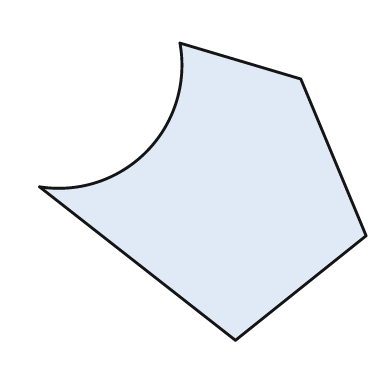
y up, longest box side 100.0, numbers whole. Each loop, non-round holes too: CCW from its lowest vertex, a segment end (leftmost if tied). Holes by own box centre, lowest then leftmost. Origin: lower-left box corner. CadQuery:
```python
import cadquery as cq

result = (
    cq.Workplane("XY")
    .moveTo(60.0, 0.0)
    .lineTo(100.0, 32.0)
    .lineTo(80.0, 80.0)
    .lineTo(43.0, 91.0)
    .threePointArc((33.0, 58.0), (0.0, 47.0))
    .close()
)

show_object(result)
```